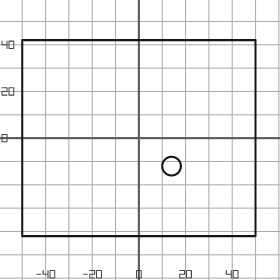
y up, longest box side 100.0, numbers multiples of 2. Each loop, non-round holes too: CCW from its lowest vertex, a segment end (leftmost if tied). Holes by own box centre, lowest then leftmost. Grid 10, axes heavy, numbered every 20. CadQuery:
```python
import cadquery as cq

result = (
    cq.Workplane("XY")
    .moveTo(-50.0, -42.0)
    .lineTo(50.0, -42.0)
    .lineTo(50.0, 42.0)
    .lineTo(-50.0, 42.0)
    .close()
    .moveTo(14.0, -12.0)
    .circle(4.0)
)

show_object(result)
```